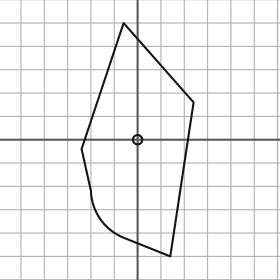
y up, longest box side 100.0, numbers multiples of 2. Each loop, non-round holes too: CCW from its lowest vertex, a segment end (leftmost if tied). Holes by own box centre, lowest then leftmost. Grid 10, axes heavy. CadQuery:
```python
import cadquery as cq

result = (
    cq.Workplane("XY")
    .moveTo(14.0, -50.0)
    .lineTo(24.0, 16.0)
    .lineTo(-6.0, 50.0)
    .lineTo(-24.0, -4.0)
    .lineTo(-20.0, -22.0)
    .threePointArc((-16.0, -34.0), (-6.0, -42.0))
    .close()
    .moveTo(0.0, 0.0)
    .circle(2.0)
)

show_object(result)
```